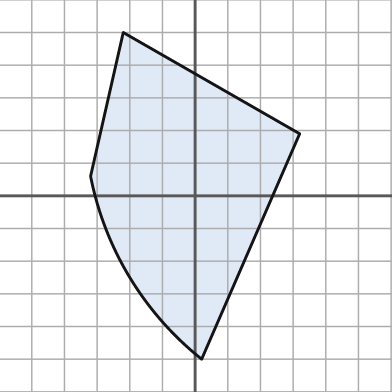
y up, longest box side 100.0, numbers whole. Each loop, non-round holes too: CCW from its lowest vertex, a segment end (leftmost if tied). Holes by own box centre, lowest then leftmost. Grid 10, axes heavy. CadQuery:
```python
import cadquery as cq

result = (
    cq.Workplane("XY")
    .moveTo(2.0, -50.0)
    .lineTo(32.0, 19.0)
    .lineTo(-22.0, 50.0)
    .lineTo(-32.0, 6.0)
    .threePointArc((-20.0, -25.0), (2.0, -50.0))
    .close()
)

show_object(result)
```